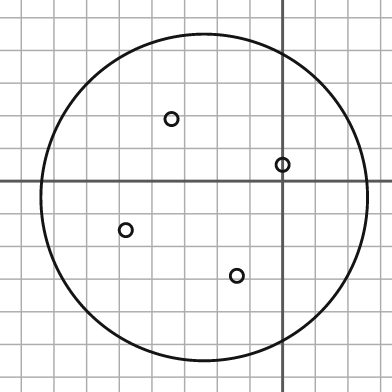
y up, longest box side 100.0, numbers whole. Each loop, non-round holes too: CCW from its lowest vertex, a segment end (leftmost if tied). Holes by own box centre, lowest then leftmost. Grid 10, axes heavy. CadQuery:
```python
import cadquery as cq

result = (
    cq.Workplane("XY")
    .moveTo(-24.0, -5.0)
    .circle(50.0)
    .moveTo(-14.0, -29.0)
    .circle(2.0)
    .moveTo(-48.0, -15.0)
    .circle(2.0)
    .moveTo(0.0, 5.0)
    .circle(2.0)
    .moveTo(-34.0, 19.0)
    .circle(2.0)
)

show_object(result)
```